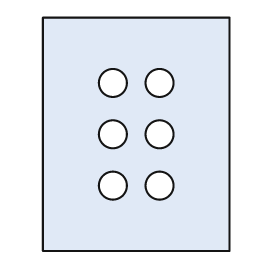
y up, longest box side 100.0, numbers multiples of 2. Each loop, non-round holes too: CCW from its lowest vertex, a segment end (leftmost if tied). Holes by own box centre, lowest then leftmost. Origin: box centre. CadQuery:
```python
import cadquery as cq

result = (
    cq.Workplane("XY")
    .moveTo(-40.0, -50.0)
    .lineTo(40.0, -50.0)
    .lineTo(40.0, 50.0)
    .lineTo(-40.0, 50.0)
    .close()
    .moveTo(-10.0, -22.0)
    .circle(6.0)
    .moveTo(10.0, -22.0)
    .circle(6.0)
    .moveTo(-10.0, 0.0)
    .circle(6.0)
    .moveTo(10.0, 0.0)
    .circle(6.0)
    .moveTo(-10.0, 22.0)
    .circle(6.0)
    .moveTo(10.0, 22.0)
    .circle(6.0)
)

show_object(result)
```